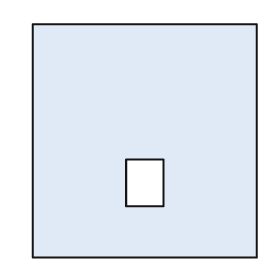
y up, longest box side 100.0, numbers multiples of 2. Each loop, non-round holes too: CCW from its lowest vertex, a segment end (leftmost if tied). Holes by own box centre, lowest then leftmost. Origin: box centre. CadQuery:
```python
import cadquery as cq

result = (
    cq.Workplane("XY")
    .moveTo(-48.0, -50.0)
    .lineTo(48.0, -50.0)
    .lineTo(48.0, 50.0)
    .lineTo(-48.0, 50.0)
    .close()
    .moveTo(-8.0, -28.0)
    .lineTo(8.0, -28.0)
    .lineTo(8.0, -8.0)
    .lineTo(-8.0, -8.0)
    .close()
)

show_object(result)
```